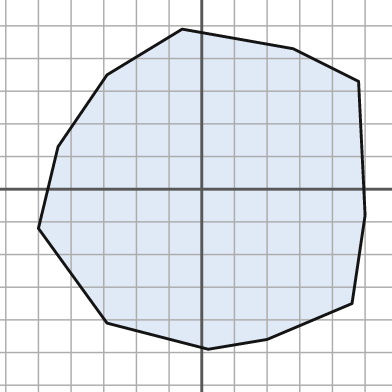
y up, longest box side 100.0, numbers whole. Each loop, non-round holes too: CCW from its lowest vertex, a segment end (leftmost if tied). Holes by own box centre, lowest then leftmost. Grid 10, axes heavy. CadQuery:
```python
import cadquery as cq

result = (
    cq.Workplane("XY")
    .moveTo(2.0, -49.0)
    .lineTo(20.0, -46.0)
    .lineTo(46.0, -35.0)
    .lineTo(50.0, -8.0)
    .lineTo(48.0, 33.0)
    .lineTo(28.0, 43.0)
    .lineTo(-6.0, 49.0)
    .lineTo(-29.0, 35.0)
    .lineTo(-44.0, 13.0)
    .lineTo(-50.0, -12.0)
    .lineTo(-29.0, -41.0)
    .close()
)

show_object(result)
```